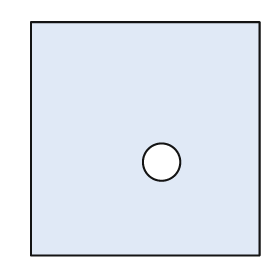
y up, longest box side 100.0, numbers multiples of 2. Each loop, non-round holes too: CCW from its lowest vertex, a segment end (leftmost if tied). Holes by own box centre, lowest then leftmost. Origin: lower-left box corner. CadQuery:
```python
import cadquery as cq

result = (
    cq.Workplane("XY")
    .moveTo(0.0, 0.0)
    .lineTo(98.0, 0.0)
    .lineTo(98.0, 100.0)
    .lineTo(0.0, 100.0)
    .close()
    .moveTo(56.0, 40.0)
    .circle(8.0)
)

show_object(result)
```